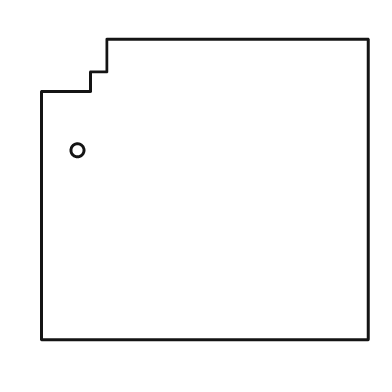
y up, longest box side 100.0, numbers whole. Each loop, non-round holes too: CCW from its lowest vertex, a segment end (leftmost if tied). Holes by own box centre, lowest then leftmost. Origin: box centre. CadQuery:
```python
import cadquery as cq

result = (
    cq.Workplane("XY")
    .moveTo(-50.0, -46.0)
    .lineTo(50.0, -46.0)
    .lineTo(50.0, 46.0)
    .lineTo(-30.0, 46.0)
    .lineTo(-30.0, 36.0)
    .lineTo(-35.0, 36.0)
    .lineTo(-35.0, 30.0)
    .lineTo(-50.0, 30.0)
    .close()
    .moveTo(-39.0, 12.0)
    .circle(2.0)
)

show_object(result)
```